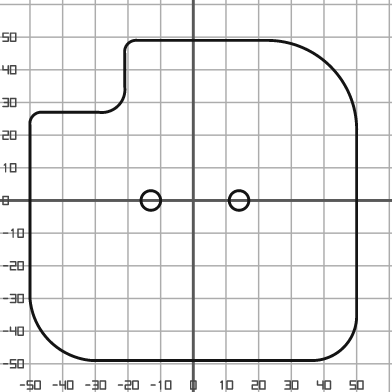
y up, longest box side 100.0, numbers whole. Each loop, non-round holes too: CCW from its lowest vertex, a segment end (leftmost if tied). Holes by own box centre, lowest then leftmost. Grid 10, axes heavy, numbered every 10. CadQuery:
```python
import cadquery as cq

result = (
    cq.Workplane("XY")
    .moveTo(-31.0, -49.0)
    .lineTo(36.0, -49.0)
    .threePointArc((46.0, -45.0), (50.0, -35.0))
    .lineTo(50.0, 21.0)
    .threePointArc((42.0, 41.0), (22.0, 49.0))
    .lineTo(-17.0, 49.0)
    .threePointArc((-20.0, 48.0), (-21.0, 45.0))
    .lineTo(-21.0, 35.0)
    .threePointArc((-23.0, 29.0), (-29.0, 27.0))
    .lineTo(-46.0, 27.0)
    .threePointArc((-49.0, 26.0), (-50.0, 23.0))
    .lineTo(-50.0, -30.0)
    .threePointArc((-44.0, -43.0), (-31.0, -49.0))
    .close()
    .moveTo(-13.0, 0.0)
    .circle(3.0)
    .moveTo(14.0, 0.0)
    .circle(3.0)
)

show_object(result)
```